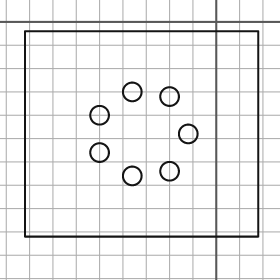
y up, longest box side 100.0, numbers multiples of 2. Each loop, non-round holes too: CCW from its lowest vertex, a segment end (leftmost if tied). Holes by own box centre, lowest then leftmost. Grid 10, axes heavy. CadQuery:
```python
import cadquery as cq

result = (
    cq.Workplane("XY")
    .moveTo(-82.0, -92.0)
    .lineTo(18.0, -92.0)
    .lineTo(18.0, -4.0)
    .lineTo(-82.0, -4.0)
    .close()
    .moveTo(-36.0, -66.0)
    .circle(4.0)
    .moveTo(-20.0, -64.0)
    .circle(4.0)
    .moveTo(-50.0, -56.0)
    .circle(4.0)
    .moveTo(-12.0, -48.0)
    .circle(4.0)
    .moveTo(-50.0, -40.0)
    .circle(4.0)
    .moveTo(-20.0, -32.0)
    .circle(4.0)
    .moveTo(-36.0, -30.0)
    .circle(4.0)
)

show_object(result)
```